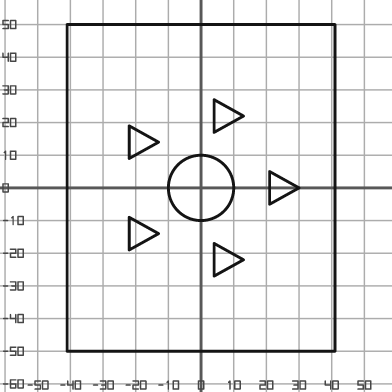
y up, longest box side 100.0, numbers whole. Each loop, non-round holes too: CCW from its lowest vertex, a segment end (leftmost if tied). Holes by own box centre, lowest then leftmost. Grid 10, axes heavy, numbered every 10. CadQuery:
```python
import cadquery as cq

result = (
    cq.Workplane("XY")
    .moveTo(-41.0, -50.0)
    .lineTo(41.0, -50.0)
    .lineTo(41.0, 50.0)
    .lineTo(-41.0, 50.0)
    .close()
    .moveTo(4.0, -27.0)
    .lineTo(13.0, -22.0)
    .lineTo(4.0, -17.0)
    .close()
    .moveTo(-22.0, -19.0)
    .lineTo(-13.0, -14.0)
    .lineTo(-22.0, -9.0)
    .close()
    .moveTo(0.0, 0.0)
    .circle(10.0)
    .moveTo(21.0, -5.0)
    .lineTo(30.0, 0.0)
    .lineTo(21.0, 5.0)
    .close()
    .moveTo(-22.0, 9.0)
    .lineTo(-13.0, 14.0)
    .lineTo(-22.0, 19.0)
    .close()
    .moveTo(4.0, 17.0)
    .lineTo(13.0, 22.0)
    .lineTo(4.0, 27.0)
    .close()
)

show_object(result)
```